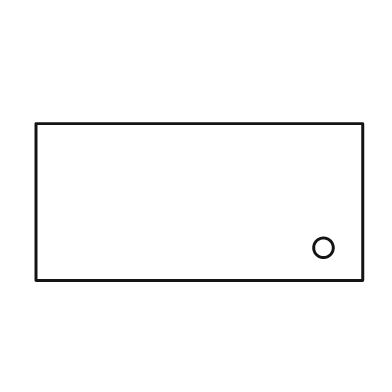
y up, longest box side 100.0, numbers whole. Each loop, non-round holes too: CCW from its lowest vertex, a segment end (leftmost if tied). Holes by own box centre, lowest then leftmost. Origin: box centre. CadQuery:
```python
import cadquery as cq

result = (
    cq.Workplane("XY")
    .moveTo(-50.0, -24.0)
    .lineTo(50.0, -24.0)
    .lineTo(50.0, 24.0)
    .lineTo(-50.0, 24.0)
    .close()
    .moveTo(38.0, -14.0)
    .circle(3.0)
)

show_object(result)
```